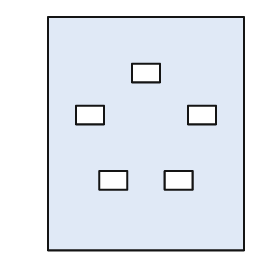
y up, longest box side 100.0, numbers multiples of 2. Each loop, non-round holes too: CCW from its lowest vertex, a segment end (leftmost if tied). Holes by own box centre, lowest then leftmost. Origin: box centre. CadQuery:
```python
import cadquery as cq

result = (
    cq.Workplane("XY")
    .moveTo(-42.0, -50.0)
    .lineTo(42.0, -50.0)
    .lineTo(42.0, 50.0)
    .lineTo(-42.0, 50.0)
    .close()
    .moveTo(-20.0, -24.0)
    .lineTo(-8.0, -24.0)
    .lineTo(-8.0, -16.0)
    .lineTo(-20.0, -16.0)
    .close()
    .moveTo(8.0, -24.0)
    .lineTo(20.0, -24.0)
    .lineTo(20.0, -16.0)
    .lineTo(8.0, -16.0)
    .close()
    .moveTo(-30.0, 4.0)
    .lineTo(-18.0, 4.0)
    .lineTo(-18.0, 12.0)
    .lineTo(-30.0, 12.0)
    .close()
    .moveTo(18.0, 4.0)
    .lineTo(30.0, 4.0)
    .lineTo(30.0, 12.0)
    .lineTo(18.0, 12.0)
    .close()
    .moveTo(-6.0, 22.0)
    .lineTo(6.0, 22.0)
    .lineTo(6.0, 30.0)
    .lineTo(-6.0, 30.0)
    .close()
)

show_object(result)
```